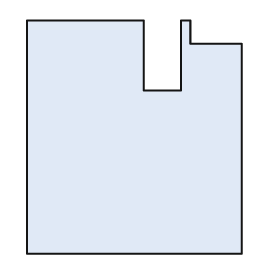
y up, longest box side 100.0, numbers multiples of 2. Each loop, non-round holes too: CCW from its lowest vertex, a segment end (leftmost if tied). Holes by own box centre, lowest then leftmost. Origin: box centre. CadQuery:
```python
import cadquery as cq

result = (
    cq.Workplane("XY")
    .moveTo(-46.0, -50.0)
    .lineTo(46.0, -50.0)
    .lineTo(46.0, 40.0)
    .lineTo(24.0, 40.0)
    .lineTo(24.0, 50.0)
    .lineTo(20.0, 50.0)
    .lineTo(20.0, 20.0)
    .lineTo(4.0, 20.0)
    .lineTo(4.0, 50.0)
    .lineTo(-46.0, 50.0)
    .close()
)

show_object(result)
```